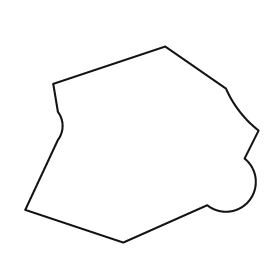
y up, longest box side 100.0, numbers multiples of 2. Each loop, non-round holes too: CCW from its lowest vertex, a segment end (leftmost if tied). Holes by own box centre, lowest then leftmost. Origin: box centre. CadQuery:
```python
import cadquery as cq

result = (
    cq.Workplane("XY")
    .moveTo(-8.0, -42.0)
    .lineTo(28.0, -26.0)
    .threePointArc((46.0, -24.0), (44.0, -6.0))
    .lineTo(50.0, 6.0)
    .threePointArc((42.0, 14.0), (36.0, 24.0))
    .lineTo(10.0, 42.0)
    .lineTo(-38.0, 26.0)
    .lineTo(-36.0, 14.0)
    .threePointArc((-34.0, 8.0), (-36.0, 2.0))
    .lineTo(-50.0, -28.0)
    .close()
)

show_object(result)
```